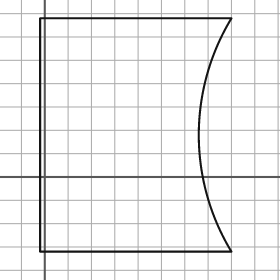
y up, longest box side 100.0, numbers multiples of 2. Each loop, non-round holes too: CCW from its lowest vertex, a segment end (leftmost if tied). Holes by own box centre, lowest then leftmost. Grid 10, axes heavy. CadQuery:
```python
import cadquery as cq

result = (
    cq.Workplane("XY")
    .moveTo(-2.0, -32.0)
    .lineTo(80.0, -32.0)
    .threePointArc((66.0, 18.0), (80.0, 68.0))
    .lineTo(-2.0, 68.0)
    .close()
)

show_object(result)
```